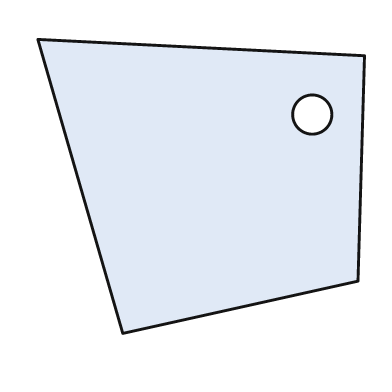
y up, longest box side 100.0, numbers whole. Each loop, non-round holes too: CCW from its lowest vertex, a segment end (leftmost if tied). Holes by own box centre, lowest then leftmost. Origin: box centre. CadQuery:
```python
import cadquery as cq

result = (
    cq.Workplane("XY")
    .moveTo(-24.0, -45.0)
    .lineTo(48.0, -29.0)
    .lineTo(50.0, 40.0)
    .lineTo(-50.0, 45.0)
    .close()
    .moveTo(34.0, 22.0)
    .circle(6.0)
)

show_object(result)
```